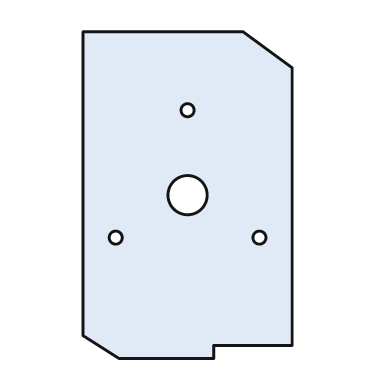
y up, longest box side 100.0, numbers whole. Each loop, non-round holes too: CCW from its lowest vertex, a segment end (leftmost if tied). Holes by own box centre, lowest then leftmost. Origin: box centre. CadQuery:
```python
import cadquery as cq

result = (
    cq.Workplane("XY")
    .moveTo(-21.0, -50.0)
    .lineTo(8.0, -50.0)
    .lineTo(8.0, -46.0)
    .lineTo(32.0, -46.0)
    .lineTo(32.0, 39.0)
    .lineTo(17.0, 50.0)
    .lineTo(-32.0, 50.0)
    .lineTo(-32.0, -43.0)
    .close()
    .moveTo(-22.0, -13.0)
    .circle(2.0)
    .moveTo(22.0, -13.0)
    .circle(2.0)
    .moveTo(0.0, 0.0)
    .circle(6.0)
    .moveTo(0.0, 26.0)
    .circle(2.0)
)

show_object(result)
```